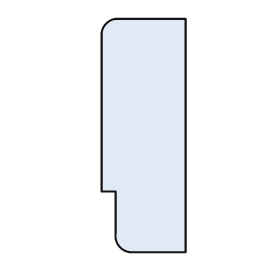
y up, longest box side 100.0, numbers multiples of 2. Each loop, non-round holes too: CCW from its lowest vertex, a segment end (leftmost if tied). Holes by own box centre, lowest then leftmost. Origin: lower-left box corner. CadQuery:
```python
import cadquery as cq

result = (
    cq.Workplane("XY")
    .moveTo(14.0, 0.0)
    .lineTo(36.0, 0.0)
    .lineTo(36.0, 100.0)
    .lineTo(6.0, 100.0)
    .threePointArc((2.0, 98.0), (0.0, 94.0))
    .lineTo(0.0, 26.0)
    .lineTo(6.0, 26.0)
    .lineTo(6.0, 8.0)
    .threePointArc((8.0, 2.0), (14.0, 0.0))
    .close()
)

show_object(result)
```